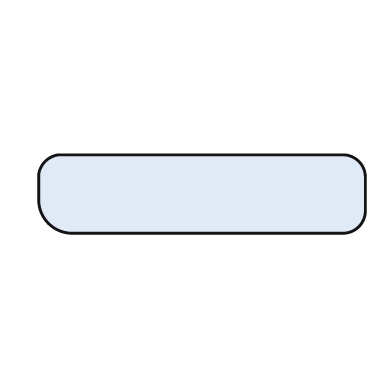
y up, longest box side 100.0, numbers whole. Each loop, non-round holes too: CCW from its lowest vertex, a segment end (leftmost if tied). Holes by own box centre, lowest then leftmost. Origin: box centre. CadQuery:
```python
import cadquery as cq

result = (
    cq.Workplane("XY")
    .moveTo(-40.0, -12.0)
    .lineTo(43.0, -12.0)
    .threePointArc((48.0, -10.0), (50.0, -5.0))
    .lineTo(50.0, 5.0)
    .threePointArc((48.0, 10.0), (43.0, 12.0))
    .lineTo(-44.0, 12.0)
    .threePointArc((-48.0, 10.0), (-50.0, 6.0))
    .lineTo(-50.0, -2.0)
    .threePointArc((-47.0, -9.0), (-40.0, -12.0))
    .close()
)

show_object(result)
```